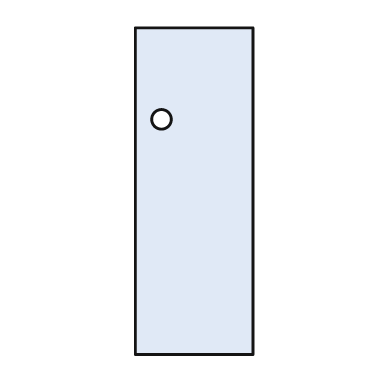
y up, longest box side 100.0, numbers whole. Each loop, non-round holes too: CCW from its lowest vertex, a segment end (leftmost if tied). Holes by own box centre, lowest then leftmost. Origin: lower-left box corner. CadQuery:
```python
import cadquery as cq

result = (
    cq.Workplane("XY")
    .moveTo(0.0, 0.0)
    .lineTo(36.0, 0.0)
    .lineTo(36.0, 100.0)
    .lineTo(0.0, 100.0)
    .close()
    .moveTo(8.0, 72.0)
    .circle(3.0)
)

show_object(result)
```